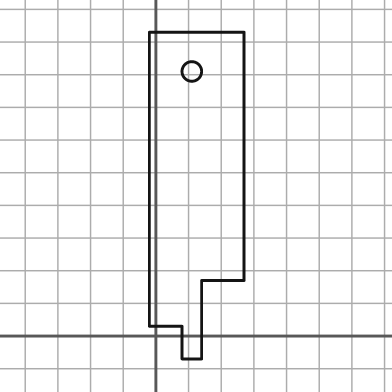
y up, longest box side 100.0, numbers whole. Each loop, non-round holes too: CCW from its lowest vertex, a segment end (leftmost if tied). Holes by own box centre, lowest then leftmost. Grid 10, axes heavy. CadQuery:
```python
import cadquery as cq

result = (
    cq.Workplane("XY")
    .moveTo(8.0, -7.0)
    .lineTo(14.0, -7.0)
    .lineTo(14.0, 17.0)
    .lineTo(27.0, 17.0)
    .lineTo(27.0, 93.0)
    .lineTo(-2.0, 93.0)
    .lineTo(-2.0, 3.0)
    .lineTo(8.0, 3.0)
    .close()
    .moveTo(11.0, 81.0)
    .circle(3.0)
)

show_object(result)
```